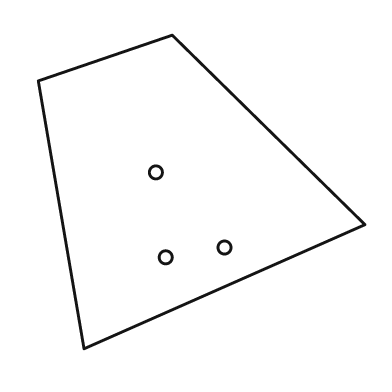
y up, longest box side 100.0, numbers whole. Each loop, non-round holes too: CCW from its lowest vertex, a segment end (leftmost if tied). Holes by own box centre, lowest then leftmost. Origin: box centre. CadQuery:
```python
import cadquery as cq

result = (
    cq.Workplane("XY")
    .moveTo(-36.0, -48.0)
    .lineTo(50.0, -10.0)
    .lineTo(-9.0, 48.0)
    .lineTo(-50.0, 34.0)
    .close()
    .moveTo(-11.0, -20.0)
    .circle(2.0)
    .moveTo(7.0, -17.0)
    .circle(2.0)
    .moveTo(-14.0, 6.0)
    .circle(2.0)
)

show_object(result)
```